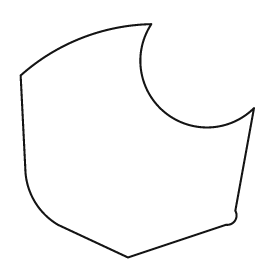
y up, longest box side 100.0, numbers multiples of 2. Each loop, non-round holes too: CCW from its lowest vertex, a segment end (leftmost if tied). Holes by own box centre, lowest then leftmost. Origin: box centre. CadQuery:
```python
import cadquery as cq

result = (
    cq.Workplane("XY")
    .moveTo(-4.0, -50.0)
    .lineTo(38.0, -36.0)
    .threePointArc((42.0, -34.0), (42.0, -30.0))
    .lineTo(50.0, 14.0)
    .threePointArc((12.0, 12.0), (6.0, 50.0))
    .threePointArc((-24.0, 44.0), (-50.0, 28.0))
    .lineTo(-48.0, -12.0)
    .threePointArc((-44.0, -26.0), (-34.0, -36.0))
    .close()
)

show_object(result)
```